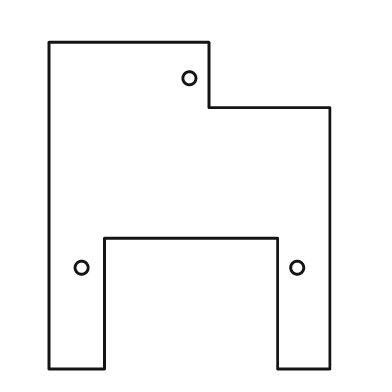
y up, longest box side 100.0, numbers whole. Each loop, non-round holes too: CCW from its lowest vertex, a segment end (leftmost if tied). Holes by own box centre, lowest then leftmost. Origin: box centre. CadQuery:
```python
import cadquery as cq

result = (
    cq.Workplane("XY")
    .moveTo(-43.0, -50.0)
    .lineTo(-26.0, -50.0)
    .lineTo(-26.0, -10.0)
    .lineTo(27.0, -10.0)
    .lineTo(27.0, -50.0)
    .lineTo(43.0, -50.0)
    .lineTo(43.0, 30.0)
    .lineTo(6.0, 30.0)
    .lineTo(6.0, 50.0)
    .lineTo(-43.0, 50.0)
    .close()
    .moveTo(-33.0, -19.0)
    .circle(2.0)
    .moveTo(33.0, -19.0)
    .circle(2.0)
    .moveTo(0.0, 39.0)
    .circle(2.0)
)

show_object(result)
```